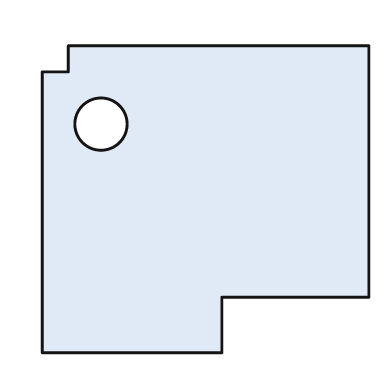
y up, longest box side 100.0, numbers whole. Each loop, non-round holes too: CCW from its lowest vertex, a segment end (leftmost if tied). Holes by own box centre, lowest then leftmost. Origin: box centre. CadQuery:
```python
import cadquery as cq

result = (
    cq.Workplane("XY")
    .moveTo(-50.0, -47.0)
    .lineTo(5.0, -47.0)
    .lineTo(5.0, -30.0)
    .lineTo(50.0, -30.0)
    .lineTo(50.0, 47.0)
    .lineTo(-42.0, 47.0)
    .lineTo(-42.0, 39.0)
    .lineTo(-50.0, 39.0)
    .close()
    .moveTo(-32.0, 23.0)
    .circle(8.0)
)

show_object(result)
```